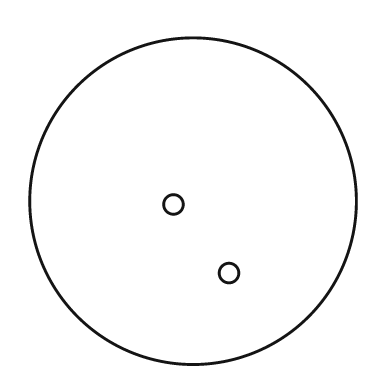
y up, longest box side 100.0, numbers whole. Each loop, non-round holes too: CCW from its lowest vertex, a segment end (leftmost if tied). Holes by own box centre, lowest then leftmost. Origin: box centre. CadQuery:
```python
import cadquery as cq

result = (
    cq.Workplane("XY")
    .moveTo(0.0, 0.0)
    .circle(50.0)
    .moveTo(11.0, -22.0)
    .circle(3.0)
    .moveTo(-6.0, -1.0)
    .circle(3.0)
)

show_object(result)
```